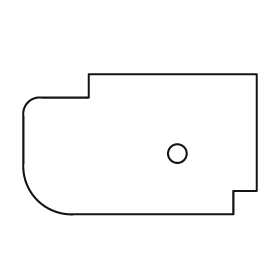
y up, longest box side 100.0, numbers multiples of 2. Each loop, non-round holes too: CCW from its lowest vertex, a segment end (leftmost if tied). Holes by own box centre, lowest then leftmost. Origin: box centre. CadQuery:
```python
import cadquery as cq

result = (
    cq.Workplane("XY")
    .moveTo(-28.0, -30.0)
    .lineTo(40.0, -30.0)
    .lineTo(40.0, -20.0)
    .lineTo(50.0, -20.0)
    .lineTo(50.0, 30.0)
    .lineTo(-22.0, 30.0)
    .lineTo(-22.0, 20.0)
    .lineTo(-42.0, 20.0)
    .threePointArc((-48.0, 18.0), (-50.0, 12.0))
    .lineTo(-50.0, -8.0)
    .threePointArc((-44.0, -24.0), (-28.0, -30.0))
    .close()
    .moveTo(16.0, -4.0)
    .circle(4.0)
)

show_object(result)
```